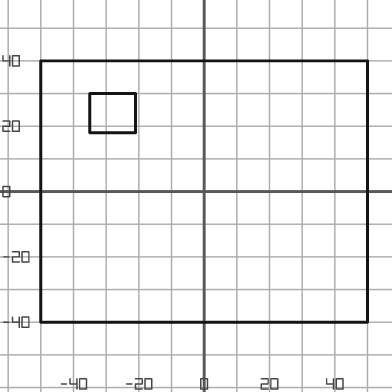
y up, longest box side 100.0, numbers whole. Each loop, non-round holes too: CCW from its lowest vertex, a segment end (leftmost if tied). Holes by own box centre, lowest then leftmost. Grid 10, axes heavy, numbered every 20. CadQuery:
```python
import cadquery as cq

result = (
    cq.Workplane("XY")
    .moveTo(-50.0, -40.0)
    .lineTo(50.0, -40.0)
    .lineTo(50.0, 40.0)
    .lineTo(-50.0, 40.0)
    .close()
    .moveTo(-35.0, 18.0)
    .lineTo(-21.0, 18.0)
    .lineTo(-21.0, 30.0)
    .lineTo(-35.0, 30.0)
    .close()
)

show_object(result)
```